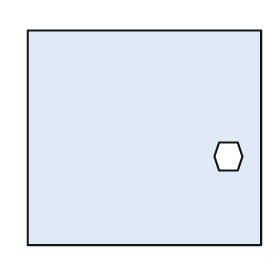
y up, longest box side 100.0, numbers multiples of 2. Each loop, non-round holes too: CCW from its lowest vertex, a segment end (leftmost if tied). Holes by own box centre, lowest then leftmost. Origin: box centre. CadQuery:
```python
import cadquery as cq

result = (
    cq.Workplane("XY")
    .moveTo(-50.0, -46.0)
    .lineTo(50.0, -46.0)
    .lineTo(50.0, 46.0)
    .lineTo(-50.0, 46.0)
    .close()
    .moveTo(32.0, -14.0)
    .lineTo(40.0, -14.0)
    .lineTo(42.0, -8.0)
    .lineTo(40.0, -2.0)
    .lineTo(32.0, -2.0)
    .lineTo(30.0, -8.0)
    .close()
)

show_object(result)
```